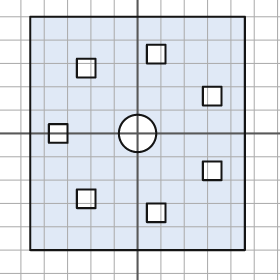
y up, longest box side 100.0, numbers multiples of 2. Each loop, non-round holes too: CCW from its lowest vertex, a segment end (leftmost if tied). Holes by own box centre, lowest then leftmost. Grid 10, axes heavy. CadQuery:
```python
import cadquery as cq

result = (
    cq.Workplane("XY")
    .moveTo(-46.0, -50.0)
    .lineTo(46.0, -50.0)
    .lineTo(46.0, 50.0)
    .lineTo(-46.0, 50.0)
    .close()
    .moveTo(4.0, -38.0)
    .lineTo(12.0, -38.0)
    .lineTo(12.0, -30.0)
    .lineTo(4.0, -30.0)
    .close()
    .moveTo(-26.0, -32.0)
    .lineTo(-18.0, -32.0)
    .lineTo(-18.0, -24.0)
    .lineTo(-26.0, -24.0)
    .close()
    .moveTo(28.0, -20.0)
    .lineTo(36.0, -20.0)
    .lineTo(36.0, -12.0)
    .lineTo(28.0, -12.0)
    .close()
    .moveTo(-38.0, -4.0)
    .lineTo(-30.0, -4.0)
    .lineTo(-30.0, 4.0)
    .lineTo(-38.0, 4.0)
    .close()
    .moveTo(0.0, 0.0)
    .circle(8.0)
    .moveTo(28.0, 12.0)
    .lineTo(36.0, 12.0)
    .lineTo(36.0, 20.0)
    .lineTo(28.0, 20.0)
    .close()
    .moveTo(-26.0, 24.0)
    .lineTo(-18.0, 24.0)
    .lineTo(-18.0, 32.0)
    .lineTo(-26.0, 32.0)
    .close()
    .moveTo(4.0, 30.0)
    .lineTo(12.0, 30.0)
    .lineTo(12.0, 38.0)
    .lineTo(4.0, 38.0)
    .close()
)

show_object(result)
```